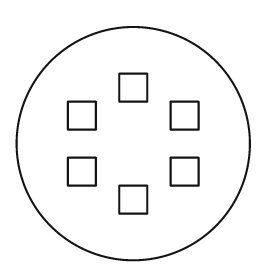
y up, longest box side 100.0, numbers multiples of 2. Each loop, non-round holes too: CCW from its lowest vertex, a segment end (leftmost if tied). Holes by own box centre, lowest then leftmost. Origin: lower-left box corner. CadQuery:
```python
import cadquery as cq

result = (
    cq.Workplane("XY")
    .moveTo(50.0, 50.0)
    .circle(50.0)
    .moveTo(44.0, 20.0)
    .lineTo(56.0, 20.0)
    .lineTo(56.0, 32.0)
    .lineTo(44.0, 32.0)
    .close()
    .moveTo(22.0, 32.0)
    .lineTo(34.0, 32.0)
    .lineTo(34.0, 44.0)
    .lineTo(22.0, 44.0)
    .close()
    .moveTo(66.0, 32.0)
    .lineTo(78.0, 32.0)
    .lineTo(78.0, 44.0)
    .lineTo(66.0, 44.0)
    .close()
    .moveTo(22.0, 56.0)
    .lineTo(34.0, 56.0)
    .lineTo(34.0, 68.0)
    .lineTo(22.0, 68.0)
    .close()
    .moveTo(66.0, 56.0)
    .lineTo(78.0, 56.0)
    .lineTo(78.0, 68.0)
    .lineTo(66.0, 68.0)
    .close()
    .moveTo(44.0, 68.0)
    .lineTo(56.0, 68.0)
    .lineTo(56.0, 80.0)
    .lineTo(44.0, 80.0)
    .close()
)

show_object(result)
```